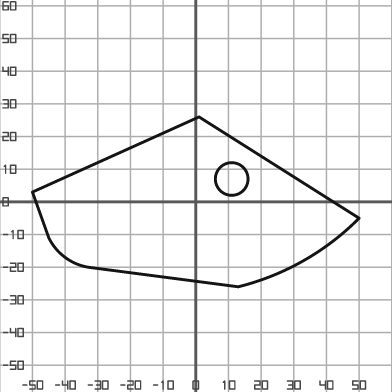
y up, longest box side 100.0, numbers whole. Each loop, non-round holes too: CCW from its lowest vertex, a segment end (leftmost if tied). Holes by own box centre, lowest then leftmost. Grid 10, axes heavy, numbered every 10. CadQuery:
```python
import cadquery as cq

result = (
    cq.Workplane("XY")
    .moveTo(13.0, -26.0)
    .threePointArc((33.0, -18.0), (50.0, -5.0))
    .lineTo(1.0, 26.0)
    .lineTo(-50.0, 3.0)
    .lineTo(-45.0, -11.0)
    .threePointArc((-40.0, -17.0), (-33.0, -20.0))
    .close()
    .moveTo(11.0, 7.0)
    .circle(5.0)
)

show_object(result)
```